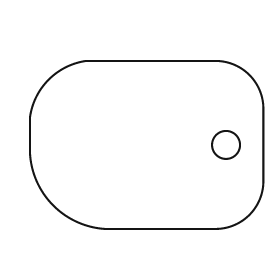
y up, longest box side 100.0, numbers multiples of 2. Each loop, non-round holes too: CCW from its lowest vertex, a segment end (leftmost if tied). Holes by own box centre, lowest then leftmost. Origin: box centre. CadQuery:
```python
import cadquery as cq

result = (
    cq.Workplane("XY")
    .moveTo(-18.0, -36.0)
    .lineTo(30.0, -36.0)
    .threePointArc((44.0, -30.0), (50.0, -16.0))
    .lineTo(50.0, 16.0)
    .threePointArc((44.0, 30.0), (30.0, 36.0))
    .lineTo(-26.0, 36.0)
    .threePointArc((-42.0, 28.0), (-50.0, 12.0))
    .lineTo(-50.0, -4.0)
    .threePointArc((-40.0, -26.0), (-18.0, -36.0))
    .close()
    .moveTo(34.0, 0.0)
    .circle(6.0)
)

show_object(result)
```